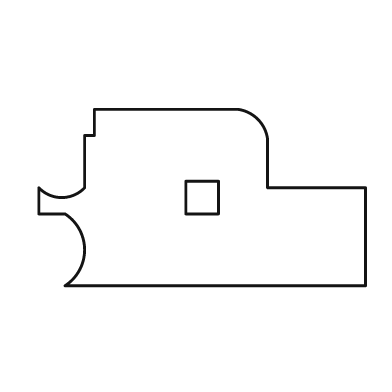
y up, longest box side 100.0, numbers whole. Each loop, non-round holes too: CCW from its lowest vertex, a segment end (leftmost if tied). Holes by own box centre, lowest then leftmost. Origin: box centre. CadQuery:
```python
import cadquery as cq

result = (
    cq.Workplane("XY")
    .moveTo(-42.0, -27.0)
    .lineTo(50.0, -27.0)
    .lineTo(50.0, 3.0)
    .lineTo(20.0, 3.0)
    .lineTo(20.0, 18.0)
    .threePointArc((17.0, 24.0), (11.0, 27.0))
    .lineTo(-33.0, 27.0)
    .lineTo(-33.0, 19.0)
    .lineTo(-36.0, 19.0)
    .lineTo(-36.0, 3.0)
    .threePointArc((-43.0, 0.0), (-50.0, 3.0))
    .lineTo(-50.0, -5.0)
    .lineTo(-42.0, -5.0)
    .threePointArc((-36.0, -16.0), (-42.0, -27.0))
    .close()
    .moveTo(-5.0, -5.0)
    .lineTo(5.0, -5.0)
    .lineTo(5.0, 5.0)
    .lineTo(-5.0, 5.0)
    .close()
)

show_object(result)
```